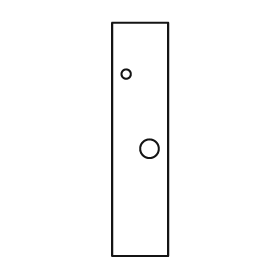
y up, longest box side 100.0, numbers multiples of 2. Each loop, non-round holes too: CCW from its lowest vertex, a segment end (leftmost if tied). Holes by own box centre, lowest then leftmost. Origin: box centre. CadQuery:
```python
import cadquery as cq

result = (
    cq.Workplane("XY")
    .moveTo(-12.0, -50.0)
    .lineTo(12.0, -50.0)
    .lineTo(12.0, 50.0)
    .lineTo(-12.0, 50.0)
    .close()
    .moveTo(4.0, -4.0)
    .circle(4.0)
    .moveTo(-6.0, 28.0)
    .circle(2.0)
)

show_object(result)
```